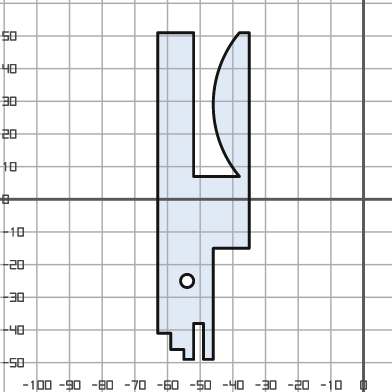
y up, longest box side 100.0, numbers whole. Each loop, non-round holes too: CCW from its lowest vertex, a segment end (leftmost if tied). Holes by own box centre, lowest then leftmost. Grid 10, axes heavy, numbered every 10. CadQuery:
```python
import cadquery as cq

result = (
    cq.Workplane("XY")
    .moveTo(-55.0, -49.0)
    .lineTo(-52.0, -49.0)
    .lineTo(-52.0, -38.0)
    .lineTo(-49.0, -38.0)
    .lineTo(-49.0, -49.0)
    .lineTo(-46.0, -49.0)
    .lineTo(-46.0, -15.0)
    .lineTo(-35.0, -15.0)
    .lineTo(-35.0, 51.0)
    .lineTo(-38.0, 51.0)
    .threePointArc((-46.0, 29.0), (-38.0, 7.0))
    .lineTo(-52.0, 7.0)
    .lineTo(-52.0, 51.0)
    .lineTo(-63.0, 51.0)
    .lineTo(-63.0, -41.0)
    .lineTo(-59.0, -41.0)
    .lineTo(-59.0, -46.0)
    .lineTo(-55.0, -46.0)
    .close()
    .moveTo(-54.0, -25.0)
    .circle(2.0)
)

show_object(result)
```